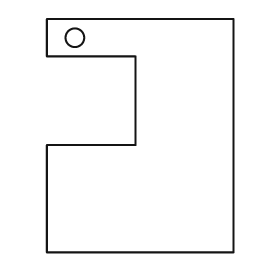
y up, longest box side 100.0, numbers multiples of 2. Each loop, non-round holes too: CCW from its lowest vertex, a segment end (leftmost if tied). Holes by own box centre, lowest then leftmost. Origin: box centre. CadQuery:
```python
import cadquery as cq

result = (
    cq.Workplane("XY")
    .moveTo(-40.0, -50.0)
    .lineTo(40.0, -50.0)
    .lineTo(40.0, 50.0)
    .lineTo(-40.0, 50.0)
    .lineTo(-40.0, 34.0)
    .lineTo(-2.0, 34.0)
    .lineTo(-2.0, -4.0)
    .lineTo(-40.0, -4.0)
    .close()
    .moveTo(-28.0, 42.0)
    .circle(4.0)
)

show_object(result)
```